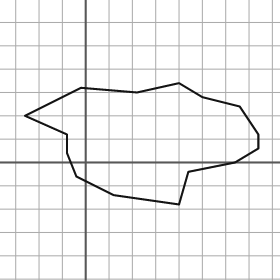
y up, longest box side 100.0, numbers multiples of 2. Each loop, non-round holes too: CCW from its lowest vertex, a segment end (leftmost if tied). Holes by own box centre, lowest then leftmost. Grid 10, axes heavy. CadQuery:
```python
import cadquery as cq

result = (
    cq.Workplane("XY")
    .moveTo(40.0, -18.0)
    .lineTo(44.0, -4.0)
    .lineTo(64.0, 0.0)
    .lineTo(74.0, 6.0)
    .lineTo(74.0, 12.0)
    .lineTo(66.0, 24.0)
    .lineTo(50.0, 28.0)
    .lineTo(40.0, 34.0)
    .lineTo(22.0, 30.0)
    .lineTo(-2.0, 32.0)
    .lineTo(-26.0, 20.0)
    .lineTo(-8.0, 12.0)
    .lineTo(-8.0, 4.0)
    .lineTo(-4.0, -6.0)
    .lineTo(12.0, -14.0)
    .close()
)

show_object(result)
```